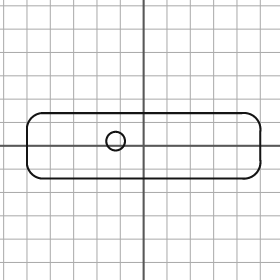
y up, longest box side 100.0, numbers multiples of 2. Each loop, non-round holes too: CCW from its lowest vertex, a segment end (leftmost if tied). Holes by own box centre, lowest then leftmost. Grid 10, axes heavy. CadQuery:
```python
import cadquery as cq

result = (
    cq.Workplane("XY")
    .moveTo(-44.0, -14.0)
    .lineTo(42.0, -14.0)
    .threePointArc((48.0, -12.0), (50.0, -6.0))
    .lineTo(50.0, 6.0)
    .threePointArc((48.0, 12.0), (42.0, 14.0))
    .lineTo(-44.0, 14.0)
    .threePointArc((-48.0, 12.0), (-50.0, 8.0))
    .lineTo(-50.0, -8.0)
    .threePointArc((-48.0, -12.0), (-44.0, -14.0))
    .close()
    .moveTo(-12.0, 2.0)
    .circle(4.0)
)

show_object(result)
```